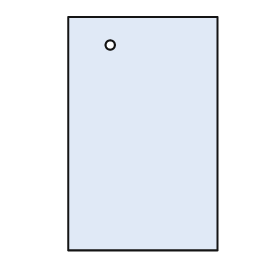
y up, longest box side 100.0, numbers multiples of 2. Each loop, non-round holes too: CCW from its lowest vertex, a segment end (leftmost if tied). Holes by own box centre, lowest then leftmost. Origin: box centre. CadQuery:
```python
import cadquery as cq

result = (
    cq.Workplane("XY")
    .moveTo(-32.0, -50.0)
    .lineTo(32.0, -50.0)
    .lineTo(32.0, 50.0)
    .lineTo(-32.0, 50.0)
    .close()
    .moveTo(-14.0, 38.0)
    .circle(2.0)
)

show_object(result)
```